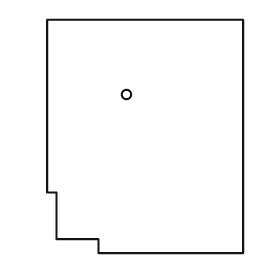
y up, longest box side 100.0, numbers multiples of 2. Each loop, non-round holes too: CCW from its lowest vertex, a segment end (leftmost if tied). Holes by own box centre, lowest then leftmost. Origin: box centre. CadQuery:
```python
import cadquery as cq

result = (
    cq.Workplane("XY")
    .moveTo(-20.0, -50.0)
    .lineTo(42.0, -50.0)
    .lineTo(42.0, 50.0)
    .lineTo(-42.0, 50.0)
    .lineTo(-42.0, -24.0)
    .lineTo(-38.0, -24.0)
    .lineTo(-38.0, -44.0)
    .lineTo(-20.0, -44.0)
    .close()
    .moveTo(-8.0, 18.0)
    .circle(2.0)
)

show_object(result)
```